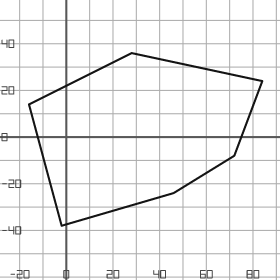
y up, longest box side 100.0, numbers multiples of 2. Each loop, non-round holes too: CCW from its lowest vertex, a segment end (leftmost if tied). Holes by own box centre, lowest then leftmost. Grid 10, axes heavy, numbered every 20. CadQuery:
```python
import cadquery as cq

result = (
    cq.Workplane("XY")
    .moveTo(-2.0, -38.0)
    .lineTo(46.0, -24.0)
    .lineTo(72.0, -8.0)
    .lineTo(84.0, 24.0)
    .lineTo(28.0, 36.0)
    .lineTo(-16.0, 14.0)
    .close()
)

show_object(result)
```